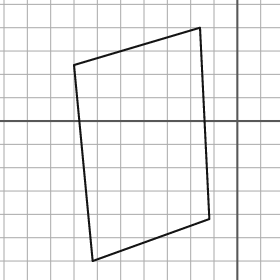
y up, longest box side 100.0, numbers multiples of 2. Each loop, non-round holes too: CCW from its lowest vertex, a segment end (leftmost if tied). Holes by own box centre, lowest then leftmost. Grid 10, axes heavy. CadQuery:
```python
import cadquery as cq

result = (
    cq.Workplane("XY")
    .moveTo(-62.0, -60.0)
    .lineTo(-12.0, -42.0)
    .lineTo(-16.0, 40.0)
    .lineTo(-70.0, 24.0)
    .close()
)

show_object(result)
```